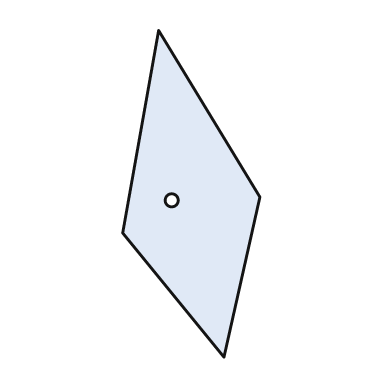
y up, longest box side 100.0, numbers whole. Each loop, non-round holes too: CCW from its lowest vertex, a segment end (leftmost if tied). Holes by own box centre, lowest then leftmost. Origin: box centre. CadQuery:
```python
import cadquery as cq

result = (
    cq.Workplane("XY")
    .moveTo(10.0, -50.0)
    .lineTo(21.0, -1.0)
    .lineTo(-10.0, 50.0)
    .lineTo(-21.0, -12.0)
    .close()
    .moveTo(-6.0, -2.0)
    .circle(2.0)
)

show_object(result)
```